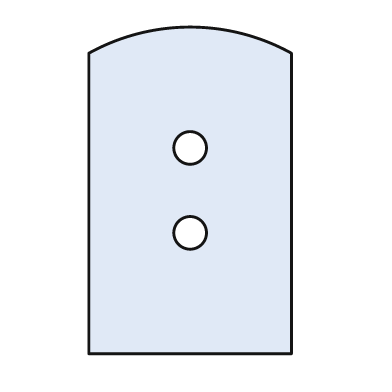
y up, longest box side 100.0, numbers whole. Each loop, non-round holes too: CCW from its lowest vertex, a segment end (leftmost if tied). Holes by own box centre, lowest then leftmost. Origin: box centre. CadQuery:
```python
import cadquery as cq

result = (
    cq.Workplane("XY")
    .moveTo(-31.0, -50.0)
    .lineTo(31.0, -50.0)
    .lineTo(31.0, 42.0)
    .threePointArc((0.0, 50.0), (-31.0, 42.0))
    .close()
    .moveTo(0.0, -13.0)
    .circle(5.0)
    .moveTo(0.0, 13.0)
    .circle(5.0)
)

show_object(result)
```